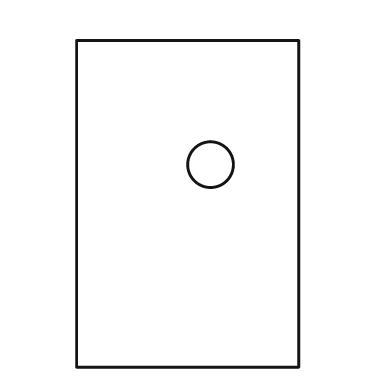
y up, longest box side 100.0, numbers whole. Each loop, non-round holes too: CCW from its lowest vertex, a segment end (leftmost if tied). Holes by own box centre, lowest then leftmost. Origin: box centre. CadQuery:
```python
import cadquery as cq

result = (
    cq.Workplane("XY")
    .moveTo(-34.0, -50.0)
    .lineTo(34.0, -50.0)
    .lineTo(34.0, 50.0)
    .lineTo(-34.0, 50.0)
    .close()
    .moveTo(7.0, 12.0)
    .circle(7.0)
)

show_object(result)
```